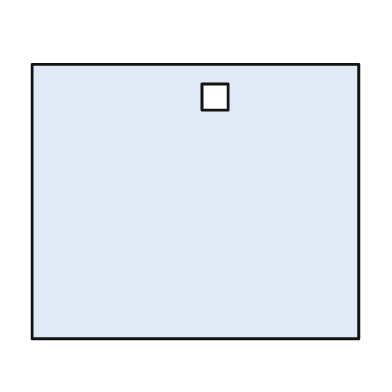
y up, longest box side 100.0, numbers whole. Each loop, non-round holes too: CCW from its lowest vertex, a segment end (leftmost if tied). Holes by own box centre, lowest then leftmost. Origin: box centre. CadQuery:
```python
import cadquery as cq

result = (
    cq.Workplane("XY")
    .moveTo(-50.0, -42.0)
    .lineTo(50.0, -42.0)
    .lineTo(50.0, 42.0)
    .lineTo(-50.0, 42.0)
    .close()
    .moveTo(2.0, 28.0)
    .lineTo(10.0, 28.0)
    .lineTo(10.0, 36.0)
    .lineTo(2.0, 36.0)
    .close()
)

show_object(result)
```